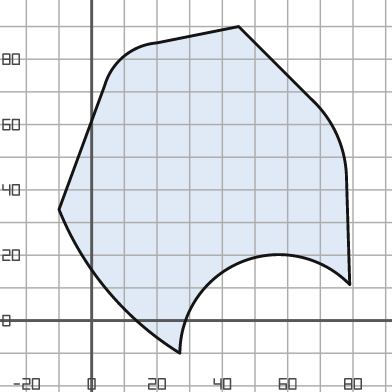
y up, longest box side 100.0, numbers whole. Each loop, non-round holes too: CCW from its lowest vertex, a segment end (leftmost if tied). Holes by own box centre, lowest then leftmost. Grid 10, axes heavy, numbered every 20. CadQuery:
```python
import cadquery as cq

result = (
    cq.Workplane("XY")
    .moveTo(27.0, -10.0)
    .threePointArc((46.0, 18.0), (79.0, 11.0))
    .lineTo(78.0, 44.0)
    .threePointArc((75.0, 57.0), (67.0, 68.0))
    .lineTo(45.0, 90.0)
    .lineTo(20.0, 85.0)
    .threePointArc((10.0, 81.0), (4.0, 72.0))
    .lineTo(-10.0, 34.0)
    .threePointArc((5.0, 9.0), (27.0, -10.0))
    .close()
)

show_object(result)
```